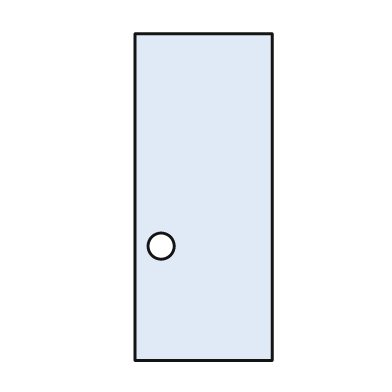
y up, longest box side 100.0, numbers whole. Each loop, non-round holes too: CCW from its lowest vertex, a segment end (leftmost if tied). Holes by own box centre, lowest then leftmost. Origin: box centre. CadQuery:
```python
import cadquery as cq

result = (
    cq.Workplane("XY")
    .moveTo(-21.0, -50.0)
    .lineTo(21.0, -50.0)
    .lineTo(21.0, 50.0)
    .lineTo(-21.0, 50.0)
    .close()
    .moveTo(-13.0, -15.0)
    .circle(4.0)
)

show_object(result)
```